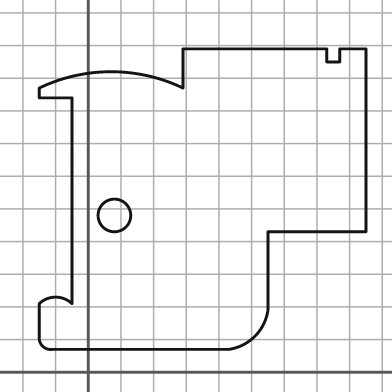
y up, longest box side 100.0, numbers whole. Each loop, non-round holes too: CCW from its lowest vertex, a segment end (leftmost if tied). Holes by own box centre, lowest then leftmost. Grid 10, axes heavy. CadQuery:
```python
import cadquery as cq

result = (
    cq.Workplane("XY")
    .moveTo(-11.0, 7.0)
    .lineTo(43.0, 7.0)
    .threePointArc((51.0, 11.0), (55.0, 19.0))
    .lineTo(55.0, 43.0)
    .lineTo(85.0, 43.0)
    .lineTo(85.0, 99.0)
    .lineTo(77.0, 99.0)
    .lineTo(77.0, 95.0)
    .lineTo(73.0, 95.0)
    .lineTo(73.0, 99.0)
    .lineTo(29.0, 99.0)
    .lineTo(29.0, 87.0)
    .threePointArc((7.0, 92.0), (-15.0, 87.0))
    .lineTo(-15.0, 84.0)
    .lineTo(-5.0, 84.0)
    .lineTo(-5.0, 21.0)
    .threePointArc((-10.0, 23.0), (-15.0, 21.0))
    .lineTo(-15.0, 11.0)
    .threePointArc((-14.0, 8.0), (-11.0, 7.0))
    .close()
    .moveTo(8.0, 48.0)
    .circle(5.0)
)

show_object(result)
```